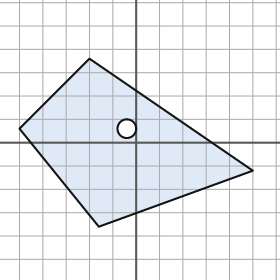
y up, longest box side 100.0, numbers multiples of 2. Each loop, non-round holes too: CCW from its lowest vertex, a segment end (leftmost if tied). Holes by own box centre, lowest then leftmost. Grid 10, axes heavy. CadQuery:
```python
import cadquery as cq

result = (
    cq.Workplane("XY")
    .moveTo(-16.0, -36.0)
    .lineTo(50.0, -12.0)
    .lineTo(-20.0, 36.0)
    .lineTo(-50.0, 6.0)
    .close()
    .moveTo(-4.0, 6.0)
    .circle(4.0)
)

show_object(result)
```